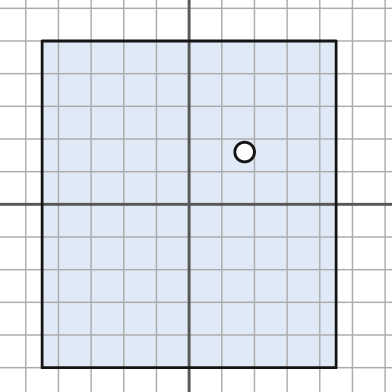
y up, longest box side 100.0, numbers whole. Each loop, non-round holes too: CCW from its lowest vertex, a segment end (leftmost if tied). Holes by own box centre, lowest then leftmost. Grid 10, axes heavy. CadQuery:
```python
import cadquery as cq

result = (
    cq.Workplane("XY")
    .moveTo(-45.0, -50.0)
    .lineTo(45.0, -50.0)
    .lineTo(45.0, 50.0)
    .lineTo(-45.0, 50.0)
    .close()
    .moveTo(17.0, 16.0)
    .circle(3.0)
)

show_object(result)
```